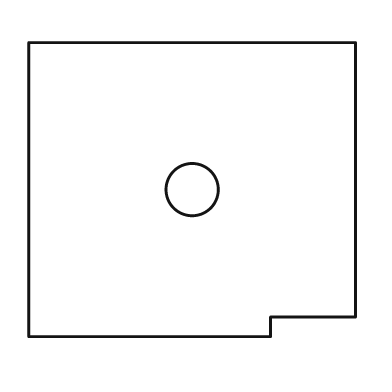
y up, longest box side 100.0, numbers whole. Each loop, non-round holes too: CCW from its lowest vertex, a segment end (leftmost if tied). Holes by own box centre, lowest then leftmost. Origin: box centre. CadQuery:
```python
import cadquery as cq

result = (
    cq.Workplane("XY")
    .moveTo(-50.0, -45.0)
    .lineTo(24.0, -45.0)
    .lineTo(24.0, -39.0)
    .lineTo(50.0, -39.0)
    .lineTo(50.0, 45.0)
    .lineTo(-50.0, 45.0)
    .close()
    .moveTo(0.0, 0.0)
    .circle(8.0)
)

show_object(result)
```